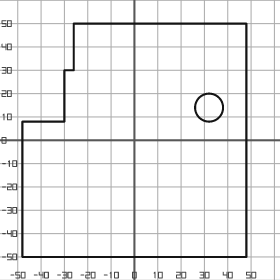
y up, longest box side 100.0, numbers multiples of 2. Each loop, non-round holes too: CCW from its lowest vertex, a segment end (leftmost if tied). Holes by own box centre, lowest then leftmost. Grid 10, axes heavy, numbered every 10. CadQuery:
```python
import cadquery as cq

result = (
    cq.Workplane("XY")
    .moveTo(-48.0, -50.0)
    .lineTo(48.0, -50.0)
    .lineTo(48.0, 50.0)
    .lineTo(-26.0, 50.0)
    .lineTo(-26.0, 30.0)
    .lineTo(-30.0, 30.0)
    .lineTo(-30.0, 8.0)
    .lineTo(-48.0, 8.0)
    .close()
    .moveTo(32.0, 14.0)
    .circle(6.0)
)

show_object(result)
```